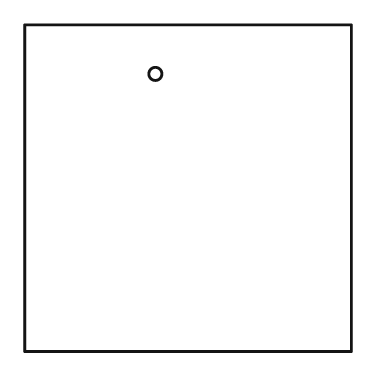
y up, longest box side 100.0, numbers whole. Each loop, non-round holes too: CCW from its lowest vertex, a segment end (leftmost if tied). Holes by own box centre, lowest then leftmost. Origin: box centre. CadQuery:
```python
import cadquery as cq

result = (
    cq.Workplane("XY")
    .moveTo(-50.0, -50.0)
    .lineTo(50.0, -50.0)
    .lineTo(50.0, 50.0)
    .lineTo(-50.0, 50.0)
    .close()
    .moveTo(-10.0, 35.0)
    .circle(2.0)
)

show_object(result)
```